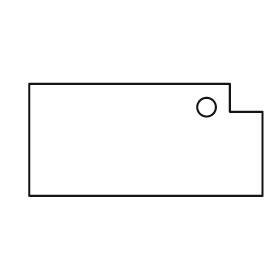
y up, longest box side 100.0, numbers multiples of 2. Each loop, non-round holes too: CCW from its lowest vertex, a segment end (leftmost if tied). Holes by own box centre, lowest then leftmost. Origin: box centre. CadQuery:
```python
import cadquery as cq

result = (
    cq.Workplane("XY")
    .moveTo(-50.0, -24.0)
    .lineTo(50.0, -24.0)
    .lineTo(50.0, 12.0)
    .lineTo(36.0, 12.0)
    .lineTo(36.0, 24.0)
    .lineTo(-50.0, 24.0)
    .close()
    .moveTo(26.0, 14.0)
    .circle(4.0)
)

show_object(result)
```